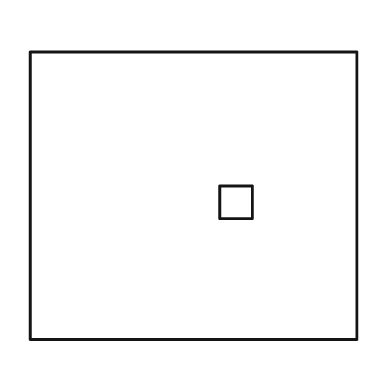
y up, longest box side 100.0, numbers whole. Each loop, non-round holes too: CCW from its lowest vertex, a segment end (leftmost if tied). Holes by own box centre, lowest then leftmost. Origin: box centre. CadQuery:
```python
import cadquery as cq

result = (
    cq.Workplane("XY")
    .moveTo(-50.0, -44.0)
    .lineTo(50.0, -44.0)
    .lineTo(50.0, 44.0)
    .lineTo(-50.0, 44.0)
    .close()
    .moveTo(8.0, -7.0)
    .lineTo(18.0, -7.0)
    .lineTo(18.0, 3.0)
    .lineTo(8.0, 3.0)
    .close()
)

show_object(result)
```